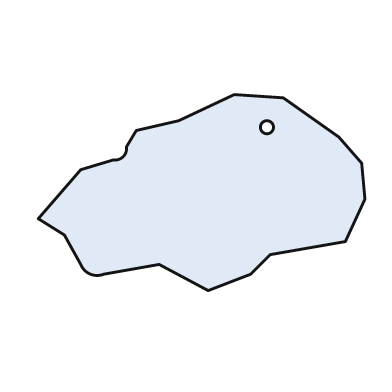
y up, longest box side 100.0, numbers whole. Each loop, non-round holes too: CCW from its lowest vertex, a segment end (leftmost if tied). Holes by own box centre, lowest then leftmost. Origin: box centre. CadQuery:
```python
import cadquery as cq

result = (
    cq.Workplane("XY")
    .moveTo(2.0, -30.0)
    .lineTo(15.0, -25.0)
    .lineTo(21.0, -19.0)
    .lineTo(44.0, -15.0)
    .lineTo(50.0, -2.0)
    .lineTo(49.0, 9.0)
    .lineTo(42.0, 17.0)
    .lineTo(25.0, 29.0)
    .lineTo(10.0, 30.0)
    .lineTo(-7.0, 22.0)
    .lineTo(-20.0, 19.0)
    .lineTo(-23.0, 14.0)
    .threePointArc((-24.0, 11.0), (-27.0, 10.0))
    .lineTo(-37.0, 7.0)
    .lineTo(-50.0, -8.0)
    .lineTo(-42.0, -13.0)
    .lineTo(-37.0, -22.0)
    .threePointArc((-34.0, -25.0), (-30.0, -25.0))
    .lineTo(-13.0, -22.0)
    .close()
    .moveTo(20.0, 20.0)
    .circle(2.0)
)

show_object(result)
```